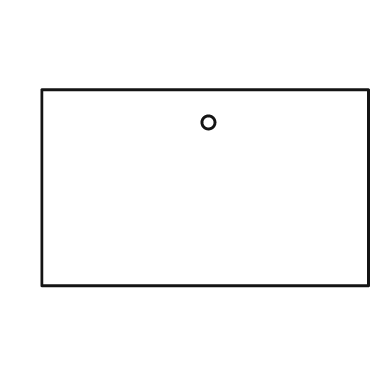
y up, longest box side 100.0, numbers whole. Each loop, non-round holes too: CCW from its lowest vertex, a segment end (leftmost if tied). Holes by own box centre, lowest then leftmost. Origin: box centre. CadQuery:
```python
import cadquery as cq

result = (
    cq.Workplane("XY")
    .moveTo(-50.0, -30.0)
    .lineTo(50.0, -30.0)
    .lineTo(50.0, 30.0)
    .lineTo(-50.0, 30.0)
    .close()
    .moveTo(1.0, 20.0)
    .circle(2.0)
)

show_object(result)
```